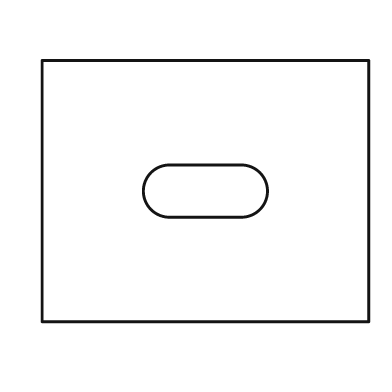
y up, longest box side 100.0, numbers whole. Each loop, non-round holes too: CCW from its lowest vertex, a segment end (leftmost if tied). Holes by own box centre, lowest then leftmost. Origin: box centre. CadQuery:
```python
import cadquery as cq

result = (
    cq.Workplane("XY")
    .moveTo(-50.0, -40.0)
    .lineTo(50.0, -40.0)
    .lineTo(50.0, 40.0)
    .lineTo(-50.0, 40.0)
    .close()
    .moveTo(-11.0, -8.0)
    .lineTo(11.0, -8.0)
    .threePointArc((19.0, 0.0), (11.0, 8.0))
    .lineTo(-11.0, 8.0)
    .threePointArc((-19.0, 0.0), (-11.0, -8.0))
    .close()
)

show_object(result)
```